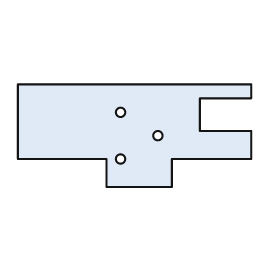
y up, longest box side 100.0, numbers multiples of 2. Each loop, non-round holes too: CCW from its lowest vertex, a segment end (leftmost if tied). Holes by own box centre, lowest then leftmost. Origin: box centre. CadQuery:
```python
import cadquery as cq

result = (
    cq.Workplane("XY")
    .moveTo(-12.0, -22.0)
    .lineTo(16.0, -22.0)
    .lineTo(16.0, -10.0)
    .lineTo(50.0, -10.0)
    .lineTo(50.0, 2.0)
    .lineTo(28.0, 2.0)
    .lineTo(28.0, 16.0)
    .lineTo(50.0, 16.0)
    .lineTo(50.0, 22.0)
    .lineTo(-50.0, 22.0)
    .lineTo(-50.0, -10.0)
    .lineTo(-12.0, -10.0)
    .close()
    .moveTo(-6.0, -10.0)
    .circle(2.0)
    .moveTo(10.0, 0.0)
    .circle(2.0)
    .moveTo(-6.0, 10.0)
    .circle(2.0)
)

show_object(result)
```